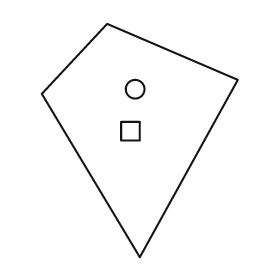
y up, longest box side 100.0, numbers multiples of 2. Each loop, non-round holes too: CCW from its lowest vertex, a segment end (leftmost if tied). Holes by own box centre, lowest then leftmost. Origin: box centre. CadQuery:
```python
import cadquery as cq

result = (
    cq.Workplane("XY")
    .moveTo(0.0, -50.0)
    .lineTo(42.0, 26.0)
    .lineTo(-14.0, 50.0)
    .lineTo(-42.0, 20.0)
    .close()
    .moveTo(-8.0, 0.0)
    .lineTo(0.0, 0.0)
    .lineTo(0.0, 8.0)
    .lineTo(-8.0, 8.0)
    .close()
    .moveTo(-2.0, 22.0)
    .circle(4.0)
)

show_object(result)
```